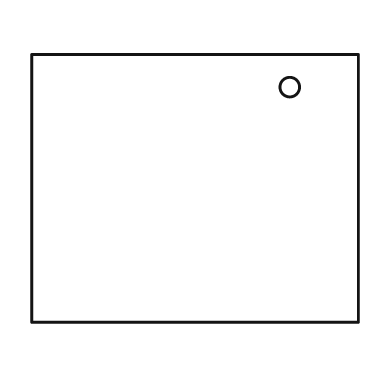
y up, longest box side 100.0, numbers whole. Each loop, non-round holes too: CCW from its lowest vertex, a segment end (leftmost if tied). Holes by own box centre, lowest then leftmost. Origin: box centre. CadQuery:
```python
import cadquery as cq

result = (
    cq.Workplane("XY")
    .moveTo(-50.0, -41.0)
    .lineTo(50.0, -41.0)
    .lineTo(50.0, 41.0)
    .lineTo(-50.0, 41.0)
    .close()
    .moveTo(29.0, 31.0)
    .circle(3.0)
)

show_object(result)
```